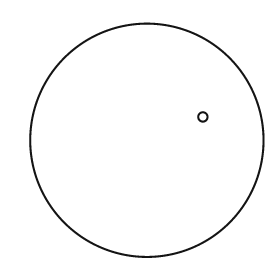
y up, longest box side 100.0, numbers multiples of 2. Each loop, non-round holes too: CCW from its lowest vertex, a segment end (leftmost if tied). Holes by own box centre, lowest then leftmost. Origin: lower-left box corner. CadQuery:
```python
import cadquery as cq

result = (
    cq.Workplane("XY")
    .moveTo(50.0, 50.0)
    .circle(50.0)
    .moveTo(74.0, 60.0)
    .circle(2.0)
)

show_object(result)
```